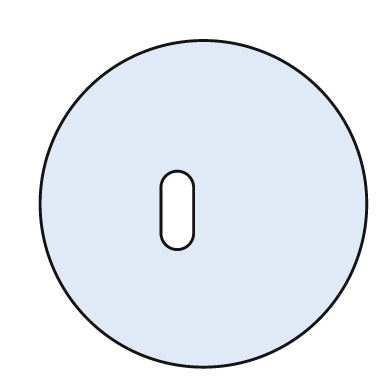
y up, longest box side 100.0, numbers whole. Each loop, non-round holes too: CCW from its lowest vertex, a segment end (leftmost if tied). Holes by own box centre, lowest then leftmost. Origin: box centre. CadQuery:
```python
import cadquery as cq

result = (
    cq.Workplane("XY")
    .moveTo(0.0, 0.0)
    .circle(50.0)
    .moveTo(-13.0, -9.0)
    .threePointArc((-8.0, -14.0), (-3.0, -9.0))
    .lineTo(-3.0, 5.0)
    .threePointArc((-8.0, 10.0), (-13.0, 5.0))
    .close()
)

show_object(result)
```